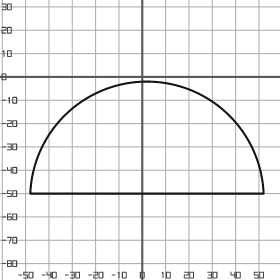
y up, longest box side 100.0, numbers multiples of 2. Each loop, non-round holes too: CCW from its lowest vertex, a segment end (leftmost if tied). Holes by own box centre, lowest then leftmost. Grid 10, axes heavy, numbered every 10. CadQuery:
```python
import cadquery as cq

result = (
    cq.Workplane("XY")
    .moveTo(-48.0, -50.0)
    .lineTo(52.0, -50.0)
    .threePointArc((2.0, -2.0), (-48.0, -50.0))
    .close()
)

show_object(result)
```